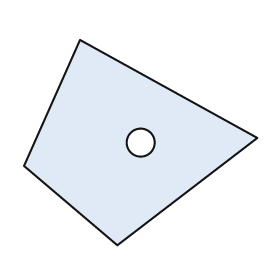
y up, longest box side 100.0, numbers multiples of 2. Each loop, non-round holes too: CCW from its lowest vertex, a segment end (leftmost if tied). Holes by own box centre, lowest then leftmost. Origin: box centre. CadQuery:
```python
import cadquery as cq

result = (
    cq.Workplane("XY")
    .moveTo(-10.0, -44.0)
    .lineTo(50.0, 2.0)
    .lineTo(-26.0, 44.0)
    .lineTo(-50.0, -10.0)
    .close()
    .moveTo(0.0, 0.0)
    .circle(6.0)
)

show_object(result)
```